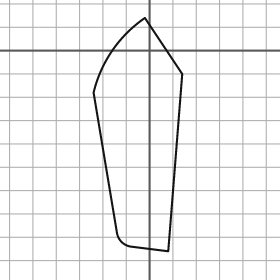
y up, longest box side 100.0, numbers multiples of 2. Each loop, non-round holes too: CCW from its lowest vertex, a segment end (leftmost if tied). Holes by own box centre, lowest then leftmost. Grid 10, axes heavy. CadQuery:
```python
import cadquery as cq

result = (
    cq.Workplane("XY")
    .moveTo(8.0, -86.0)
    .lineTo(14.0, -10.0)
    .lineTo(-2.0, 14.0)
    .threePointArc((-16.0, 0.0), (-24.0, -18.0))
    .lineTo(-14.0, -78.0)
    .threePointArc((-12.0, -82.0), (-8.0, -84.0))
    .close()
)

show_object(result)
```